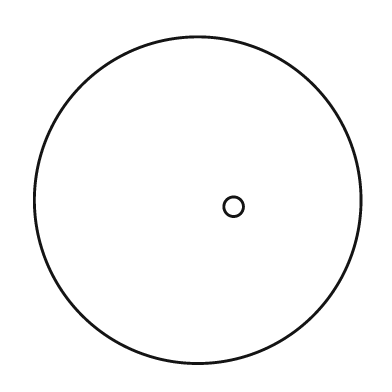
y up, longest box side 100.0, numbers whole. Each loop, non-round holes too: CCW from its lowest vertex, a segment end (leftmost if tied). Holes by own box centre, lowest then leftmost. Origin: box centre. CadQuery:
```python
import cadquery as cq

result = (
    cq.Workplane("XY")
    .moveTo(0.0, 0.0)
    .circle(50.0)
    .moveTo(11.0, -2.0)
    .circle(3.0)
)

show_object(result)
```